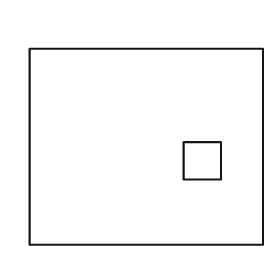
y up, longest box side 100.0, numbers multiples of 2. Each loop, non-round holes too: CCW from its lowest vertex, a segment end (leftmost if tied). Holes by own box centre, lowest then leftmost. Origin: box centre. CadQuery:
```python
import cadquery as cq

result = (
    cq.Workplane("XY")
    .moveTo(-50.0, -42.0)
    .lineTo(50.0, -42.0)
    .lineTo(50.0, 42.0)
    .lineTo(-50.0, 42.0)
    .close()
    .moveTo(16.0, -14.0)
    .lineTo(32.0, -14.0)
    .lineTo(32.0, 2.0)
    .lineTo(16.0, 2.0)
    .close()
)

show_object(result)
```